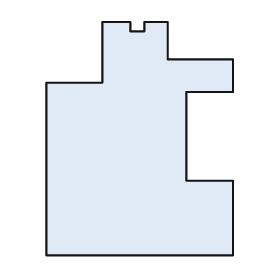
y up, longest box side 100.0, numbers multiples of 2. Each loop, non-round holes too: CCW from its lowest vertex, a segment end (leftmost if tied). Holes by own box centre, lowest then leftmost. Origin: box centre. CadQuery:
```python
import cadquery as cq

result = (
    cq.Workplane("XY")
    .moveTo(-40.0, -50.0)
    .lineTo(40.0, -50.0)
    .lineTo(40.0, -18.0)
    .lineTo(20.0, -18.0)
    .lineTo(20.0, 20.0)
    .lineTo(40.0, 20.0)
    .lineTo(40.0, 34.0)
    .lineTo(12.0, 34.0)
    .lineTo(12.0, 50.0)
    .lineTo(2.0, 50.0)
    .lineTo(2.0, 46.0)
    .lineTo(-4.0, 46.0)
    .lineTo(-4.0, 50.0)
    .lineTo(-16.0, 50.0)
    .lineTo(-16.0, 24.0)
    .lineTo(-40.0, 24.0)
    .close()
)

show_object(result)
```